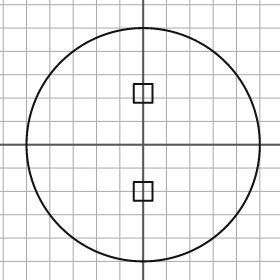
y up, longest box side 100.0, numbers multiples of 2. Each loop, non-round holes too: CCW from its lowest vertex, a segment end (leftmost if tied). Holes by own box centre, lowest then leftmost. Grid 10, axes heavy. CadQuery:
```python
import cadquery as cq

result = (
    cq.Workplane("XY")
    .moveTo(0.0, 0.0)
    .circle(50.0)
    .moveTo(-4.0, -24.0)
    .lineTo(4.0, -24.0)
    .lineTo(4.0, -16.0)
    .lineTo(-4.0, -16.0)
    .close()
    .moveTo(-4.0, 18.0)
    .lineTo(4.0, 18.0)
    .lineTo(4.0, 26.0)
    .lineTo(-4.0, 26.0)
    .close()
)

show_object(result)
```